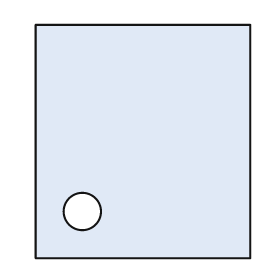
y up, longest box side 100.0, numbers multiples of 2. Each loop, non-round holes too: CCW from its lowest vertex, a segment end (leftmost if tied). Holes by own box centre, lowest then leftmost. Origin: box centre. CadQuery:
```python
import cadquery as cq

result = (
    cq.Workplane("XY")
    .moveTo(-46.0, -50.0)
    .lineTo(46.0, -50.0)
    .lineTo(46.0, 50.0)
    .lineTo(-46.0, 50.0)
    .close()
    .moveTo(-26.0, -30.0)
    .circle(8.0)
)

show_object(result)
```